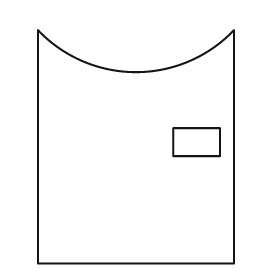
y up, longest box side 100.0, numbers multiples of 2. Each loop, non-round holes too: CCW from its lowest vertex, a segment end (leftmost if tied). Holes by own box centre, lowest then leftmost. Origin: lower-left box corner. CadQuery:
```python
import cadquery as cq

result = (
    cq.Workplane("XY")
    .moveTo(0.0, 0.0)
    .lineTo(84.0, 0.0)
    .lineTo(84.0, 100.0)
    .threePointArc((42.0, 82.0), (0.0, 100.0))
    .close()
    .moveTo(58.0, 46.0)
    .lineTo(78.0, 46.0)
    .lineTo(78.0, 58.0)
    .lineTo(58.0, 58.0)
    .close()
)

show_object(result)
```